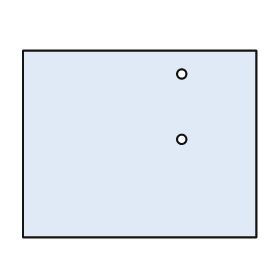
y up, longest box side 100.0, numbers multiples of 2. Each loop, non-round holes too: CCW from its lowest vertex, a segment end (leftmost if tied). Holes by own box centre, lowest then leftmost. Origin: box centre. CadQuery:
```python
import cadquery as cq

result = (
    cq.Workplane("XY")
    .moveTo(-50.0, -40.0)
    .lineTo(50.0, -40.0)
    .lineTo(50.0, 40.0)
    .lineTo(-50.0, 40.0)
    .close()
    .moveTo(18.0, 2.0)
    .circle(2.0)
    .moveTo(18.0, 30.0)
    .circle(2.0)
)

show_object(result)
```